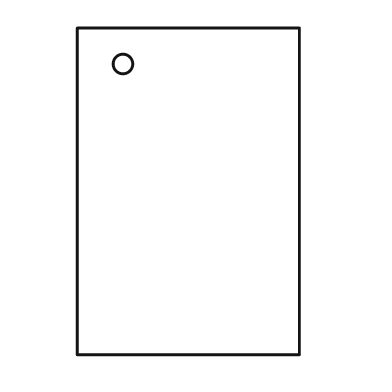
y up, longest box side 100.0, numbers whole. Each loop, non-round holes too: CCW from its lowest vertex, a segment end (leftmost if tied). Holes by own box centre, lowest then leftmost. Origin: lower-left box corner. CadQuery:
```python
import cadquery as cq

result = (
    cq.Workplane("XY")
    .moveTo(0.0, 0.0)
    .lineTo(68.0, 0.0)
    .lineTo(68.0, 100.0)
    .lineTo(0.0, 100.0)
    .close()
    .moveTo(14.0, 89.0)
    .circle(3.0)
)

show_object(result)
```